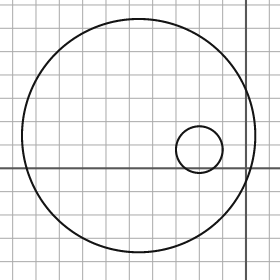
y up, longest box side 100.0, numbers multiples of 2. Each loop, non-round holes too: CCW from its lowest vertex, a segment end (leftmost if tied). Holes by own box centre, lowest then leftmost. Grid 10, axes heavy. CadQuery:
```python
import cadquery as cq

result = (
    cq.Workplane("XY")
    .moveTo(-46.0, 14.0)
    .circle(50.0)
    .moveTo(-20.0, 8.0)
    .circle(10.0)
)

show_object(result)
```